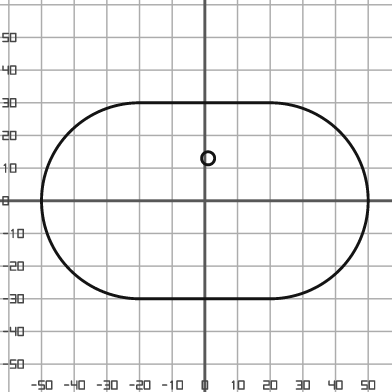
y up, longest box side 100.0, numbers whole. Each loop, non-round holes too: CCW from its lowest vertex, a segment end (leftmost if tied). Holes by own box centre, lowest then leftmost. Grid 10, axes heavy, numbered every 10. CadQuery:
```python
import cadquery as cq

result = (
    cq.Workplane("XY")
    .moveTo(-20.0, -30.0)
    .lineTo(20.0, -30.0)
    .threePointArc((50.0, 0.0), (20.0, 30.0))
    .lineTo(-20.0, 30.0)
    .threePointArc((-50.0, 0.0), (-20.0, -30.0))
    .close()
    .moveTo(1.0, 13.0)
    .circle(2.0)
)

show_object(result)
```